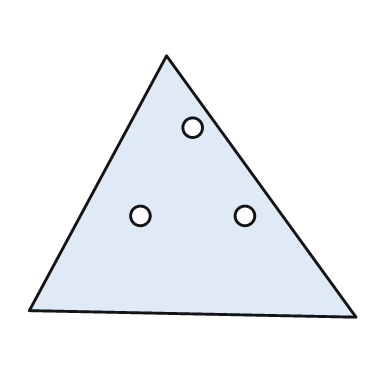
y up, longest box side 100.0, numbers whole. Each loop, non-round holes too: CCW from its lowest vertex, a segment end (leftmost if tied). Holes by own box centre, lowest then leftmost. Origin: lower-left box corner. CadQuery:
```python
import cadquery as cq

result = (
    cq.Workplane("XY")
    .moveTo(100.0, 0.0)
    .lineTo(42.0, 80.0)
    .lineTo(0.0, 2.0)
    .close()
    .moveTo(34.0, 31.0)
    .circle(3.0)
    .moveTo(66.0, 31.0)
    .circle(3.0)
    .moveTo(50.0, 58.0)
    .circle(3.0)
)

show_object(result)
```